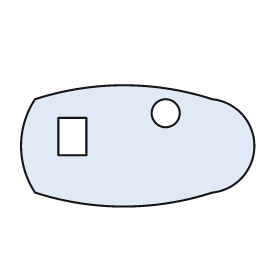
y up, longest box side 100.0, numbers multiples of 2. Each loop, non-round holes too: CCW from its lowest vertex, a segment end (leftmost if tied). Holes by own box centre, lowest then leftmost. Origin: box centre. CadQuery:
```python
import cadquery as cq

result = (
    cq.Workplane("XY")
    .moveTo(-44.0, -20.0)
    .threePointArc((-6.0, -26.0), (32.0, -20.0))
    .threePointArc((50.0, 0.0), (32.0, 20.0))
    .threePointArc((-6.0, 26.0), (-44.0, 20.0))
    .threePointArc((-50.0, 0.0), (-44.0, -20.0))
    .close()
    .moveTo(-34.0, -4.0)
    .lineTo(-22.0, -4.0)
    .lineTo(-22.0, 12.0)
    .lineTo(-34.0, 12.0)
    .close()
    .moveTo(12.0, 14.0)
    .circle(6.0)
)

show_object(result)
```